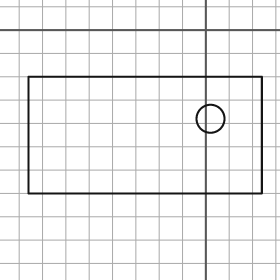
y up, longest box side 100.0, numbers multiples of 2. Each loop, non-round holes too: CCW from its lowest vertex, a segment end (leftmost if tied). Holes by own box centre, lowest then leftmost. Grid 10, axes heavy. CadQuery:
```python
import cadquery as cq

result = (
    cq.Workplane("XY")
    .moveTo(-76.0, -70.0)
    .lineTo(24.0, -70.0)
    .lineTo(24.0, -20.0)
    .lineTo(-76.0, -20.0)
    .close()
    .moveTo(2.0, -38.0)
    .circle(6.0)
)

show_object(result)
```